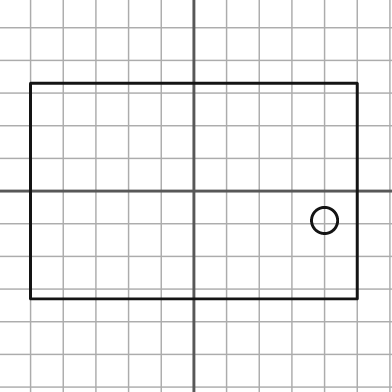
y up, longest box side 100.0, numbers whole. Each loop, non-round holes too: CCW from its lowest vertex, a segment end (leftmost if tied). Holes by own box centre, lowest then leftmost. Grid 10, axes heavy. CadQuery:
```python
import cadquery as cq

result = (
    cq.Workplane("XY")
    .moveTo(-50.0, -33.0)
    .lineTo(50.0, -33.0)
    .lineTo(50.0, 33.0)
    .lineTo(-50.0, 33.0)
    .close()
    .moveTo(40.0, -9.0)
    .circle(4.0)
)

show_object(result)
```